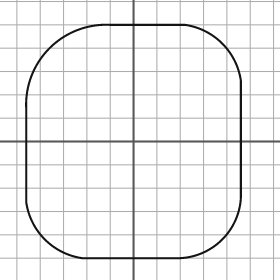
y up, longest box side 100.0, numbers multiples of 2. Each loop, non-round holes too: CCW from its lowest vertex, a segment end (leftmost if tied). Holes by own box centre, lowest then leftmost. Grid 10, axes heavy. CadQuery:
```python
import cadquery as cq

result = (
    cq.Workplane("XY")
    .moveTo(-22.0, -50.0)
    .lineTo(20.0, -50.0)
    .threePointArc((38.0, -42.0), (46.0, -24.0))
    .lineTo(46.0, 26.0)
    .threePointArc((38.0, 42.0), (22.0, 50.0))
    .lineTo(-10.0, 50.0)
    .threePointArc((-36.0, 40.0), (-46.0, 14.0))
    .lineTo(-46.0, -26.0)
    .threePointArc((-38.0, -42.0), (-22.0, -50.0))
    .close()
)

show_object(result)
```